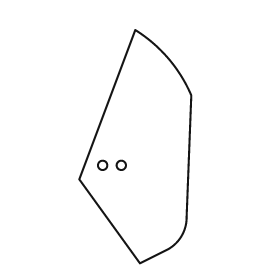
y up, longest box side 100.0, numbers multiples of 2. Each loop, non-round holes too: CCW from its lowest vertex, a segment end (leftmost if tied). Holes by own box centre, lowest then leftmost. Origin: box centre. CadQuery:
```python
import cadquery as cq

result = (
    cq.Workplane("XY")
    .moveTo(2.0, -50.0)
    .lineTo(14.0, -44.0)
    .threePointArc((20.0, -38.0), (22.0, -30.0))
    .lineTo(24.0, 22.0)
    .threePointArc((14.0, 38.0), (0.0, 50.0))
    .lineTo(-24.0, -14.0)
    .close()
    .moveTo(-14.0, -8.0)
    .circle(2.0)
    .moveTo(-6.0, -8.0)
    .circle(2.0)
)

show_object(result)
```